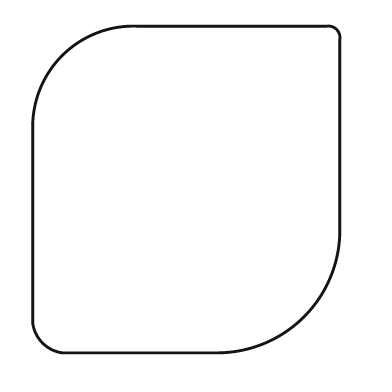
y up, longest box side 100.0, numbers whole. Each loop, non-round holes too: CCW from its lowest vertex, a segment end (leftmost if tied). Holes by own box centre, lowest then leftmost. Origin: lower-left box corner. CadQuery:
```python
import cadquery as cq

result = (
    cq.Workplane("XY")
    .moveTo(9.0, 0.0)
    .lineTo(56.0, 0.0)
    .threePointArc((83.0, 11.0), (94.0, 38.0))
    .lineTo(94.0, 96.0)
    .threePointArc((93.0, 99.0), (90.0, 100.0))
    .lineTo(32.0, 100.0)
    .threePointArc((9.0, 91.0), (0.0, 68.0))
    .lineTo(0.0, 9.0)
    .threePointArc((3.0, 3.0), (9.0, 0.0))
    .close()
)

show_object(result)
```